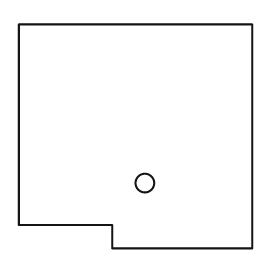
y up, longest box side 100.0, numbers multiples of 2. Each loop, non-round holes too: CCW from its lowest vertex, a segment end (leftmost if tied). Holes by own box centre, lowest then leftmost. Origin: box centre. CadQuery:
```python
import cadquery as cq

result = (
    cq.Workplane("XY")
    .moveTo(-10.0, -48.0)
    .lineTo(50.0, -48.0)
    .lineTo(50.0, 48.0)
    .lineTo(-50.0, 48.0)
    .lineTo(-50.0, -38.0)
    .lineTo(-10.0, -38.0)
    .close()
    .moveTo(4.0, -20.0)
    .circle(4.0)
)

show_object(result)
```